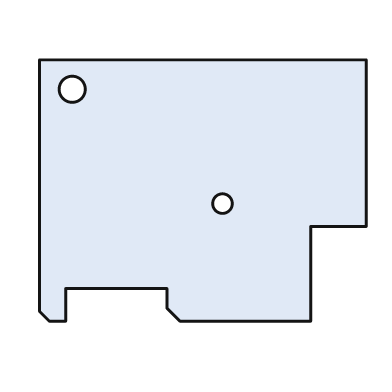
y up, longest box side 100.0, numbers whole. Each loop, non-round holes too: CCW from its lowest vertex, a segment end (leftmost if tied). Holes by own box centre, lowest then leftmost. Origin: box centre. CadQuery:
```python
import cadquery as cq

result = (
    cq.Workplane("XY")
    .moveTo(-47.0, -40.0)
    .lineTo(-42.0, -40.0)
    .lineTo(-42.0, -30.0)
    .lineTo(-11.0, -30.0)
    .lineTo(-11.0, -36.0)
    .lineTo(-7.0, -40.0)
    .lineTo(33.0, -40.0)
    .lineTo(33.0, -11.0)
    .lineTo(50.0, -11.0)
    .lineTo(50.0, 40.0)
    .lineTo(-50.0, 40.0)
    .lineTo(-50.0, -37.0)
    .close()
    .moveTo(6.0, -4.0)
    .circle(3.0)
    .moveTo(-40.0, 31.0)
    .circle(4.0)
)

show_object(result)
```